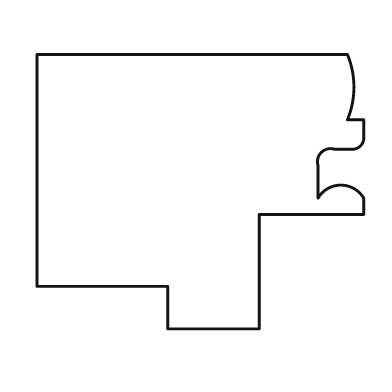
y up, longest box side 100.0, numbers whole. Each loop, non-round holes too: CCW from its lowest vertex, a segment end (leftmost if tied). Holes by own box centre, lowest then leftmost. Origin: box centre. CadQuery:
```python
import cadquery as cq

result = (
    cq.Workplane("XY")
    .moveTo(-10.0, -42.0)
    .lineTo(18.0, -42.0)
    .lineTo(18.0, -7.0)
    .lineTo(50.0, -7.0)
    .lineTo(50.0, -2.0)
    .threePointArc((43.0, 2.0), (36.0, -2.0))
    .lineTo(36.0, 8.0)
    .threePointArc((37.0, 12.0), (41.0, 13.0))
    .lineTo(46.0, 13.0)
    .threePointArc((49.0, 14.0), (50.0, 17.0))
    .lineTo(50.0, 22.0)
    .lineTo(45.0, 22.0)
    .threePointArc((47.0, 32.0), (45.0, 42.0))
    .lineTo(-50.0, 42.0)
    .lineTo(-50.0, -29.0)
    .lineTo(-10.0, -29.0)
    .close()
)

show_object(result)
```